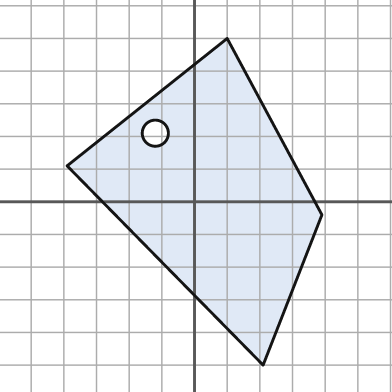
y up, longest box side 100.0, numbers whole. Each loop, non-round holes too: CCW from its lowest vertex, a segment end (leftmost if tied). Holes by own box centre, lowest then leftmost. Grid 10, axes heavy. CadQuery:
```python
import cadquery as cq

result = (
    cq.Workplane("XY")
    .moveTo(21.0, -50.0)
    .lineTo(39.0, -4.0)
    .lineTo(10.0, 50.0)
    .lineTo(-39.0, 11.0)
    .close()
    .moveTo(-12.0, 21.0)
    .circle(4.0)
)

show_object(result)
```